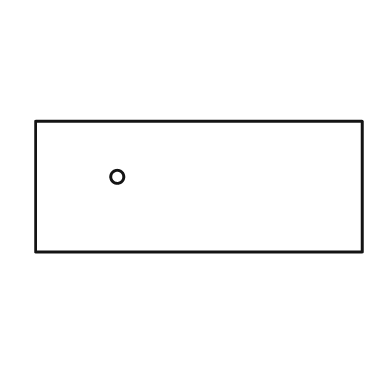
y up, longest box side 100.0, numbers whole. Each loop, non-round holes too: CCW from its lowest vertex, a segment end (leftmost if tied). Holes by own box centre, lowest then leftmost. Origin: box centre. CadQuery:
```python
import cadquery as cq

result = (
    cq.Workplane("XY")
    .moveTo(-50.0, -20.0)
    .lineTo(50.0, -20.0)
    .lineTo(50.0, 20.0)
    .lineTo(-50.0, 20.0)
    .close()
    .moveTo(-25.0, 3.0)
    .circle(2.0)
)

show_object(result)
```